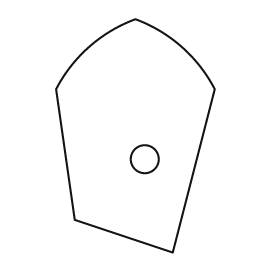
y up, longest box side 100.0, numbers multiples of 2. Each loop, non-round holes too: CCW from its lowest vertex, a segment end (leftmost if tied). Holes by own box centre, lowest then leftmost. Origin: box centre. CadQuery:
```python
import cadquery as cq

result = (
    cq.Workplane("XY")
    .moveTo(16.0, -50.0)
    .lineTo(34.0, 20.0)
    .threePointArc((20.0, 38.0), (0.0, 50.0))
    .threePointArc((-20.0, 38.0), (-34.0, 20.0))
    .lineTo(-26.0, -36.0)
    .close()
    .moveTo(4.0, -10.0)
    .circle(6.0)
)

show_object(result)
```